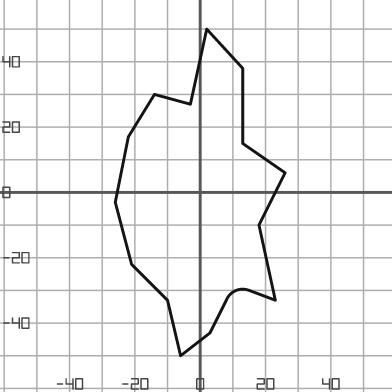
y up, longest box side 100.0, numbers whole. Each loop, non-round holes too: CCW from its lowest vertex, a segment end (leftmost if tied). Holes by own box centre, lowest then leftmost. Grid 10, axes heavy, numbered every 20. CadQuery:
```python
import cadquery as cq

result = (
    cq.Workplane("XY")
    .moveTo(-6.0, -50.0)
    .lineTo(3.0, -43.0)
    .lineTo(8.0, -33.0)
    .threePointArc((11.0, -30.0), (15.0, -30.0))
    .lineTo(23.0, -33.0)
    .lineTo(18.0, -10.0)
    .lineTo(26.0, 6.0)
    .lineTo(13.0, 15.0)
    .lineTo(13.0, 38.0)
    .lineTo(2.0, 50.0)
    .lineTo(-3.0, 27.0)
    .lineTo(-14.0, 30.0)
    .lineTo(-22.0, 17.0)
    .lineTo(-26.0, -3.0)
    .lineTo(-21.0, -22.0)
    .lineTo(-10.0, -33.0)
    .close()
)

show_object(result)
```